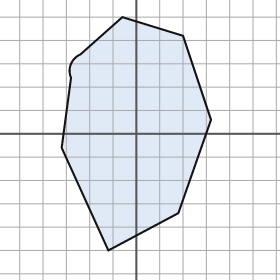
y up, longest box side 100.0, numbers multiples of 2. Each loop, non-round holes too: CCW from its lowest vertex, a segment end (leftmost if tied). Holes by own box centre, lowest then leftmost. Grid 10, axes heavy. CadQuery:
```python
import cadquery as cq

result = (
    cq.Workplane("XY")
    .moveTo(-12.0, -50.0)
    .lineTo(18.0, -34.0)
    .lineTo(32.0, 6.0)
    .lineTo(20.0, 42.0)
    .lineTo(-6.0, 50.0)
    .lineTo(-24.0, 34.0)
    .threePointArc((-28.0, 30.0), (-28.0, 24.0))
    .lineTo(-32.0, -6.0)
    .close()
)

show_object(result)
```